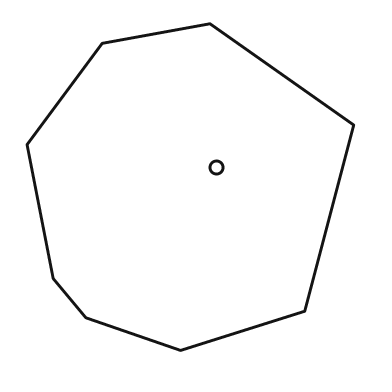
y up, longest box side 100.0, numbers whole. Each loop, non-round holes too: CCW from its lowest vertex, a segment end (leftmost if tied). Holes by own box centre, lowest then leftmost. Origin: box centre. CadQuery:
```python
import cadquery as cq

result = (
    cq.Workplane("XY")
    .moveTo(-3.0, -50.0)
    .lineTo(35.0, -38.0)
    .lineTo(50.0, 19.0)
    .lineTo(6.0, 50.0)
    .lineTo(-27.0, 44.0)
    .lineTo(-50.0, 13.0)
    .lineTo(-42.0, -28.0)
    .lineTo(-32.0, -40.0)
    .close()
    .moveTo(8.0, 6.0)
    .circle(2.0)
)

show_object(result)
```